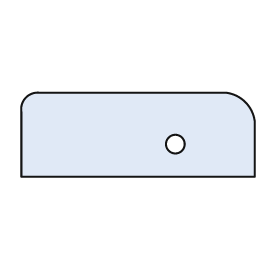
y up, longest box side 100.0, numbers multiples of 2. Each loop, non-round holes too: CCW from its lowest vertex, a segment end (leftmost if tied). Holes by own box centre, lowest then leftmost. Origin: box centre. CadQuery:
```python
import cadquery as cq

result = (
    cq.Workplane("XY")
    .moveTo(-50.0, -18.0)
    .lineTo(50.0, -18.0)
    .lineTo(50.0, 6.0)
    .threePointArc((46.0, 14.0), (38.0, 18.0))
    .lineTo(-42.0, 18.0)
    .threePointArc((-48.0, 16.0), (-50.0, 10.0))
    .close()
    .moveTo(16.0, -4.0)
    .circle(4.0)
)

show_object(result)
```